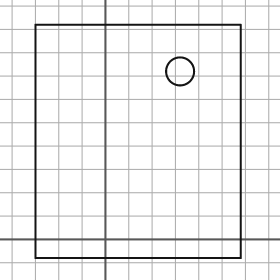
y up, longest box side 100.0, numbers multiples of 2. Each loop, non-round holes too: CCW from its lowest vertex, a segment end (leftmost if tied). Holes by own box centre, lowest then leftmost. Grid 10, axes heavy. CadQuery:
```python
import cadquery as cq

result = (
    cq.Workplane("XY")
    .moveTo(-30.0, -8.0)
    .lineTo(58.0, -8.0)
    .lineTo(58.0, 92.0)
    .lineTo(-30.0, 92.0)
    .close()
    .moveTo(32.0, 72.0)
    .circle(6.0)
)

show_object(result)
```